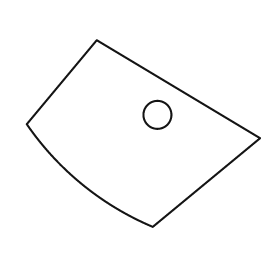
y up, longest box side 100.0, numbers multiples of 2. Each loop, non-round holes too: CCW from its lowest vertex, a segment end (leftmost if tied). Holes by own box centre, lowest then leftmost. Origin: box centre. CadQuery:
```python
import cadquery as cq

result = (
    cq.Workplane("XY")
    .moveTo(4.0, -40.0)
    .lineTo(50.0, -2.0)
    .lineTo(-20.0, 40.0)
    .lineTo(-50.0, 4.0)
    .threePointArc((-26.0, -22.0), (4.0, -40.0))
    .close()
    .moveTo(6.0, 8.0)
    .circle(6.0)
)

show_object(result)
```